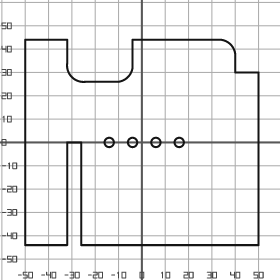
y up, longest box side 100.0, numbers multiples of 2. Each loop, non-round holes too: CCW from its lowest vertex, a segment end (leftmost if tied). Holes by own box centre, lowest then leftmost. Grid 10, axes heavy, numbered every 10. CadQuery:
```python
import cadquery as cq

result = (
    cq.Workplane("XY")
    .moveTo(-50.0, -44.0)
    .lineTo(-32.0, -44.0)
    .lineTo(-32.0, 0.0)
    .lineTo(-26.0, 0.0)
    .lineTo(-26.0, -44.0)
    .lineTo(50.0, -44.0)
    .lineTo(50.0, 30.0)
    .lineTo(40.0, 30.0)
    .lineTo(40.0, 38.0)
    .threePointArc((38.0, 42.0), (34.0, 44.0))
    .lineTo(-4.0, 44.0)
    .lineTo(-4.0, 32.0)
    .threePointArc((-6.0, 28.0), (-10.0, 26.0))
    .lineTo(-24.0, 26.0)
    .threePointArc((-30.0, 28.0), (-32.0, 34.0))
    .lineTo(-32.0, 44.0)
    .lineTo(-50.0, 44.0)
    .close()
    .moveTo(-14.0, 0.0)
    .circle(2.0)
    .moveTo(-4.0, 0.0)
    .circle(2.0)
    .moveTo(6.0, 0.0)
    .circle(2.0)
    .moveTo(16.0, 0.0)
    .circle(2.0)
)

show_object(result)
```